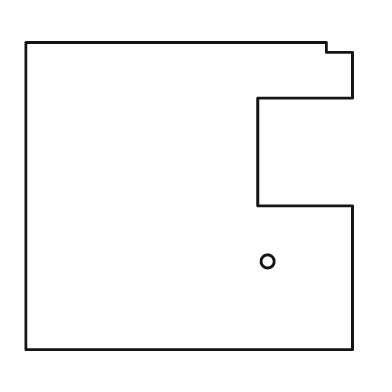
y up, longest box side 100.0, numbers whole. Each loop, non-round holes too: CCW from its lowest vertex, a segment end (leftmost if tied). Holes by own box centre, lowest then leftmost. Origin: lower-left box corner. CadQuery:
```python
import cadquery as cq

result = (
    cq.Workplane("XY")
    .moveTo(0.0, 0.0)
    .lineTo(100.0, 0.0)
    .lineTo(100.0, 44.0)
    .lineTo(71.0, 44.0)
    .lineTo(71.0, 77.0)
    .lineTo(100.0, 77.0)
    .lineTo(100.0, 91.0)
    .lineTo(92.0, 91.0)
    .lineTo(92.0, 94.0)
    .lineTo(0.0, 94.0)
    .close()
    .moveTo(74.0, 27.0)
    .circle(2.0)
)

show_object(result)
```